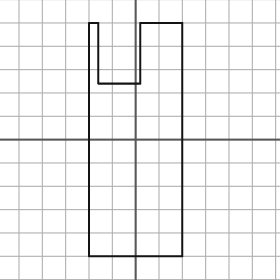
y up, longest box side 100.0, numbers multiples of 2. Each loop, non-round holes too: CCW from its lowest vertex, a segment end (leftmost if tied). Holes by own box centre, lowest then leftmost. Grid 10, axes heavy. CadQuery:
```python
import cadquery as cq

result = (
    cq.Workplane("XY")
    .moveTo(-20.0, -50.0)
    .lineTo(20.0, -50.0)
    .lineTo(20.0, 50.0)
    .lineTo(2.0, 50.0)
    .lineTo(2.0, 24.0)
    .lineTo(-16.0, 24.0)
    .lineTo(-16.0, 50.0)
    .lineTo(-20.0, 50.0)
    .close()
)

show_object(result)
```